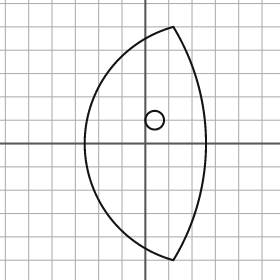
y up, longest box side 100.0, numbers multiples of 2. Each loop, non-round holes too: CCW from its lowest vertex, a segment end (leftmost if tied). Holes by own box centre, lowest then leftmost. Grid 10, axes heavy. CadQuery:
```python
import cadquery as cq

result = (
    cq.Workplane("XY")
    .moveTo(12.0, -50.0)
    .threePointArc((26.0, 0.0), (12.0, 50.0))
    .threePointArc((-26.0, 0.0), (12.0, -50.0))
    .close()
    .moveTo(4.0, 10.0)
    .circle(4.0)
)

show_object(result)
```